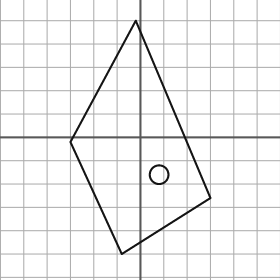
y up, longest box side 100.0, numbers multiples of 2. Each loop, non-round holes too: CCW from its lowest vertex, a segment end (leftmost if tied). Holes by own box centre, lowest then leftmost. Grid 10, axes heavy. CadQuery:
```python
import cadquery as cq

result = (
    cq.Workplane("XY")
    .moveTo(-8.0, -50.0)
    .lineTo(30.0, -26.0)
    .lineTo(-2.0, 50.0)
    .lineTo(-30.0, -2.0)
    .close()
    .moveTo(8.0, -16.0)
    .circle(4.0)
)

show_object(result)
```